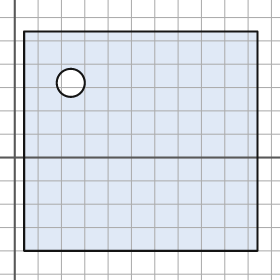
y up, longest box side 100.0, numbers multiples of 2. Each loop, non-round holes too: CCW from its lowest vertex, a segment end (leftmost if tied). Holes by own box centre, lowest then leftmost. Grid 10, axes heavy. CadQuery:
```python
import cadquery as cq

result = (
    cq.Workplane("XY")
    .moveTo(4.0, -40.0)
    .lineTo(104.0, -40.0)
    .lineTo(104.0, 54.0)
    .lineTo(4.0, 54.0)
    .close()
    .moveTo(24.0, 32.0)
    .circle(6.0)
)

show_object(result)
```